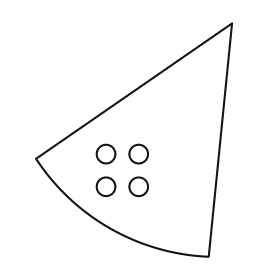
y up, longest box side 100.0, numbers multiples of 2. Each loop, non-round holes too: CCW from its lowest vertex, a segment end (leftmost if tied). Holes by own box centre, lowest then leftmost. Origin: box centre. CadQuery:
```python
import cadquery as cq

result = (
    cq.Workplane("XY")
    .moveTo(32.0, -50.0)
    .lineTo(42.0, 50.0)
    .lineTo(-42.0, -8.0)
    .threePointArc((-10.0, -38.0), (32.0, -50.0))
    .close()
    .moveTo(-12.0, -20.0)
    .circle(4.0)
    .moveTo(2.0, -20.0)
    .circle(4.0)
    .moveTo(-12.0, -6.0)
    .circle(4.0)
    .moveTo(2.0, -6.0)
    .circle(4.0)
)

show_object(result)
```